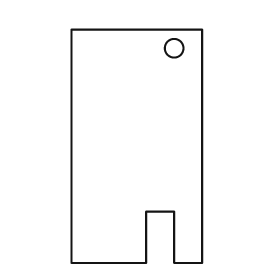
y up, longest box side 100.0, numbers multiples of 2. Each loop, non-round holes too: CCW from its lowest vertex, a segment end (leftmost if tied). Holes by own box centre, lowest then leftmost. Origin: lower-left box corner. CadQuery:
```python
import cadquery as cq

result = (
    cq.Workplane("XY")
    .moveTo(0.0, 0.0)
    .lineTo(32.0, 0.0)
    .lineTo(32.0, 22.0)
    .lineTo(44.0, 22.0)
    .lineTo(44.0, 0.0)
    .lineTo(56.0, 0.0)
    .lineTo(56.0, 100.0)
    .lineTo(0.0, 100.0)
    .close()
    .moveTo(44.0, 92.0)
    .circle(4.0)
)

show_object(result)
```